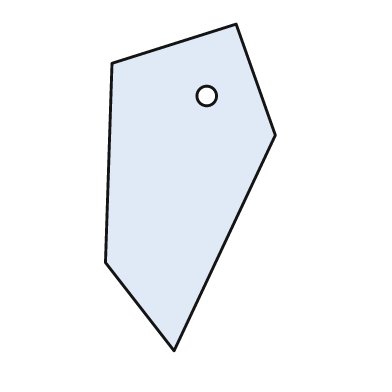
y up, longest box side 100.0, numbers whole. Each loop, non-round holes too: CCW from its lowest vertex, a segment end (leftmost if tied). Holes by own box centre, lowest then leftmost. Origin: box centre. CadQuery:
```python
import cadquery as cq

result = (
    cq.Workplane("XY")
    .moveTo(-5.0, -50.0)
    .lineTo(26.0, 16.0)
    .lineTo(14.0, 50.0)
    .lineTo(-24.0, 38.0)
    .lineTo(-26.0, -23.0)
    .close()
    .moveTo(5.0, 28.0)
    .circle(3.0)
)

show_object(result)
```